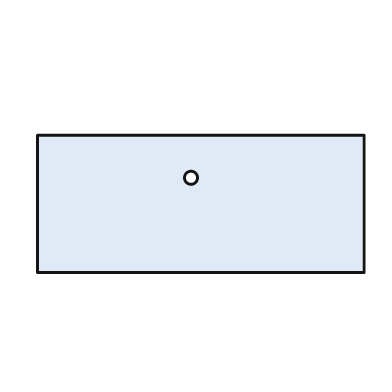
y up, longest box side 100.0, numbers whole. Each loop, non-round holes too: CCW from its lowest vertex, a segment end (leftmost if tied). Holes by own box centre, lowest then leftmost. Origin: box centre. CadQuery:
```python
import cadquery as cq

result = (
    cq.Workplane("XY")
    .moveTo(-50.0, -21.0)
    .lineTo(50.0, -21.0)
    .lineTo(50.0, 21.0)
    .lineTo(-50.0, 21.0)
    .close()
    .moveTo(-3.0, 8.0)
    .circle(2.0)
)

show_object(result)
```